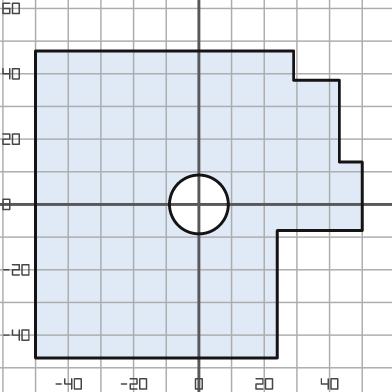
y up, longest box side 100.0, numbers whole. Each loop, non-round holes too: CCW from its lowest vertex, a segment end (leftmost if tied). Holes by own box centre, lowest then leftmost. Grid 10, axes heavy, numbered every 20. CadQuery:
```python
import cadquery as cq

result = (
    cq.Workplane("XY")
    .moveTo(-50.0, -47.0)
    .lineTo(24.0, -47.0)
    .lineTo(24.0, -8.0)
    .lineTo(50.0, -8.0)
    .lineTo(50.0, 13.0)
    .lineTo(43.0, 13.0)
    .lineTo(43.0, 38.0)
    .lineTo(29.0, 38.0)
    .lineTo(29.0, 47.0)
    .lineTo(-50.0, 47.0)
    .close()
    .moveTo(0.0, 0.0)
    .circle(9.0)
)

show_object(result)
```